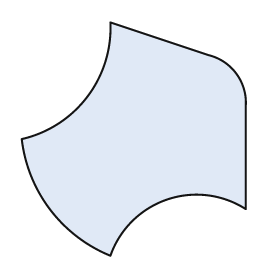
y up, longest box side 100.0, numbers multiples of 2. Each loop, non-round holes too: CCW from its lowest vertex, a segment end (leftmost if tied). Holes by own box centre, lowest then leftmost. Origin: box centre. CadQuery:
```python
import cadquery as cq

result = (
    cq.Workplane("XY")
    .moveTo(-10.0, -50.0)
    .threePointArc((14.0, -26.0), (48.0, -30.0))
    .lineTo(48.0, 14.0)
    .threePointArc((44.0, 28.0), (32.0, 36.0))
    .lineTo(-10.0, 50.0)
    .threePointArc((-20.0, 18.0), (-48.0, 0.0))
    .threePointArc((-36.0, -30.0), (-10.0, -50.0))
    .close()
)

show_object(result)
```